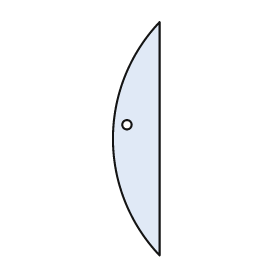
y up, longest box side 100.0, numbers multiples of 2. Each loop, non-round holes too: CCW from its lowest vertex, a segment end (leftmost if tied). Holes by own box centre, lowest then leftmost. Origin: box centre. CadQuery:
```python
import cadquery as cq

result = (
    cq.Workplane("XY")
    .moveTo(10.0, -50.0)
    .lineTo(10.0, 50.0)
    .threePointArc((-10.0, 0.0), (10.0, -50.0))
    .close()
    .moveTo(-4.0, 6.0)
    .circle(2.0)
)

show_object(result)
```